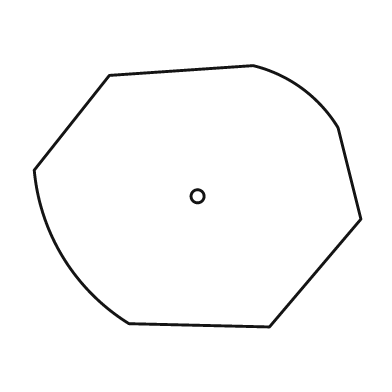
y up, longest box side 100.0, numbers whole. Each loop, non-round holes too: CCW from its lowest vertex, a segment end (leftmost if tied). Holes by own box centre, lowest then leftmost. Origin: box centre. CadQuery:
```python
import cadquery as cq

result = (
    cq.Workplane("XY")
    .moveTo(22.0, -40.0)
    .lineTo(50.0, -7.0)
    .lineTo(43.0, 21.0)
    .threePointArc((32.0, 33.0), (17.0, 40.0))
    .lineTo(-27.0, 37.0)
    .lineTo(-50.0, 8.0)
    .threePointArc((-41.0, -19.0), (-21.0, -39.0))
    .close()
    .moveTo(0.0, 0.0)
    .circle(2.0)
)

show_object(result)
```